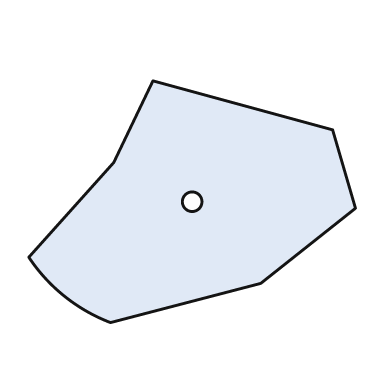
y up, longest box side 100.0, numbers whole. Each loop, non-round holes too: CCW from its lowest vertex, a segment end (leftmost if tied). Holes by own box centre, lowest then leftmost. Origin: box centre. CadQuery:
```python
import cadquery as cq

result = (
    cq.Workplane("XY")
    .moveTo(-25.0, -37.0)
    .lineTo(21.0, -25.0)
    .lineTo(50.0, -2.0)
    .lineTo(43.0, 22.0)
    .lineTo(-12.0, 37.0)
    .lineTo(-24.0, 12.0)
    .lineTo(-50.0, -17.0)
    .threePointArc((-39.0, -29.0), (-25.0, -37.0))
    .close()
    .moveTo(0.0, 0.0)
    .circle(3.0)
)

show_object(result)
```